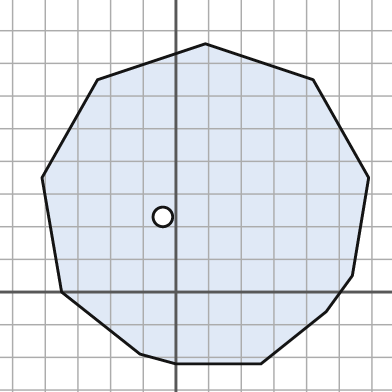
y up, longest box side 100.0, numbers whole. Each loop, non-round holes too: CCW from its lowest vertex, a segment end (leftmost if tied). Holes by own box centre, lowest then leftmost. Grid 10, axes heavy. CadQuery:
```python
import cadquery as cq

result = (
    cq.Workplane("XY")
    .moveTo(0.0, -22.0)
    .lineTo(26.0, -22.0)
    .lineTo(46.0, -6.0)
    .lineTo(54.0, 5.0)
    .lineTo(59.0, 35.0)
    .lineTo(42.0, 65.0)
    .lineTo(9.0, 76.0)
    .lineTo(-24.0, 65.0)
    .lineTo(-41.0, 35.0)
    .lineTo(-35.0, 0.0)
    .lineTo(-11.0, -19.0)
    .close()
    .moveTo(-4.0, 23.0)
    .circle(3.0)
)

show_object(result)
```